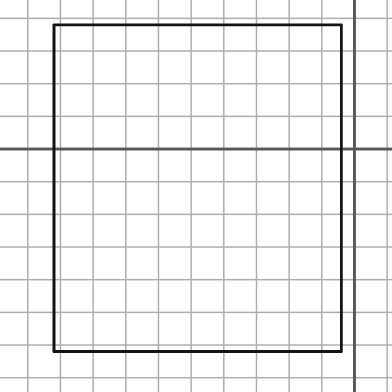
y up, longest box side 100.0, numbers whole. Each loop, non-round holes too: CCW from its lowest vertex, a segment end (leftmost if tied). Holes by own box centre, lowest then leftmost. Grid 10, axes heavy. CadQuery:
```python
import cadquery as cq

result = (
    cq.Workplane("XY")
    .moveTo(-92.0, -62.0)
    .lineTo(-4.0, -62.0)
    .lineTo(-4.0, 38.0)
    .lineTo(-92.0, 38.0)
    .close()
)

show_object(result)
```